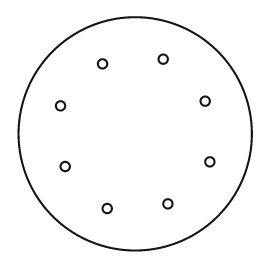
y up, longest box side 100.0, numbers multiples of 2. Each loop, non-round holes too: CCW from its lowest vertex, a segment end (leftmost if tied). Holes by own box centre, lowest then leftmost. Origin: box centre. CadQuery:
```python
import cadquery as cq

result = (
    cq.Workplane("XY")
    .moveTo(0.0, 0.0)
    .circle(50.0)
    .moveTo(-12.0, -32.0)
    .circle(2.0)
    .moveTo(14.0, -30.0)
    .circle(2.0)
    .moveTo(-30.0, -14.0)
    .circle(2.0)
    .moveTo(32.0, -12.0)
    .circle(2.0)
    .moveTo(-32.0, 12.0)
    .circle(2.0)
    .moveTo(30.0, 14.0)
    .circle(2.0)
    .moveTo(-14.0, 30.0)
    .circle(2.0)
    .moveTo(12.0, 32.0)
    .circle(2.0)
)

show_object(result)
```